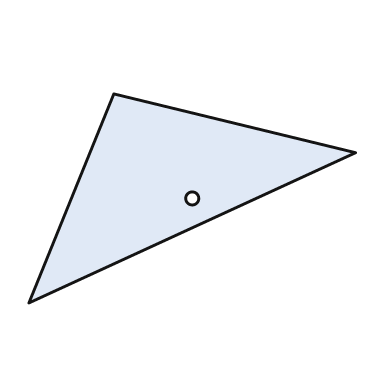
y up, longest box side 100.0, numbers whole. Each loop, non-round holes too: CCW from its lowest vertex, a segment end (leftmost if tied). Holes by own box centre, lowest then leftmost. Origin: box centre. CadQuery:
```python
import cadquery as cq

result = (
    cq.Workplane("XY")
    .moveTo(-50.0, -32.0)
    .lineTo(50.0, 14.0)
    .lineTo(-24.0, 32.0)
    .close()
    .moveTo(0.0, 0.0)
    .circle(2.0)
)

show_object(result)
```